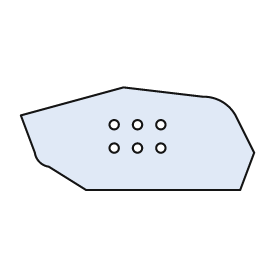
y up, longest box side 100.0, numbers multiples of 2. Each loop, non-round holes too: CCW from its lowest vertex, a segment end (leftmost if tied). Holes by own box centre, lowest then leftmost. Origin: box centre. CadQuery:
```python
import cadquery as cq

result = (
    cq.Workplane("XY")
    .moveTo(-22.0, -22.0)
    .lineTo(44.0, -22.0)
    .lineTo(50.0, -6.0)
    .lineTo(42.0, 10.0)
    .threePointArc((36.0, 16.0), (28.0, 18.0))
    .lineTo(-6.0, 22.0)
    .lineTo(-50.0, 10.0)
    .lineTo(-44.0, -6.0)
    .threePointArc((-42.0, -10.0), (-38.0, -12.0))
    .close()
    .moveTo(-10.0, -4.0)
    .circle(2.0)
    .moveTo(0.0, -4.0)
    .circle(2.0)
    .moveTo(10.0, -4.0)
    .circle(2.0)
    .moveTo(-10.0, 6.0)
    .circle(2.0)
    .moveTo(0.0, 6.0)
    .circle(2.0)
    .moveTo(10.0, 6.0)
    .circle(2.0)
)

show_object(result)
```